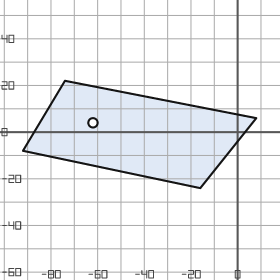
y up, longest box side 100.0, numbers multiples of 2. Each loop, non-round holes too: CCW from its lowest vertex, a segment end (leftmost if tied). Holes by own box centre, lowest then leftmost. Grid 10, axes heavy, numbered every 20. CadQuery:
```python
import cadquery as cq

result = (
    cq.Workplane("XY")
    .moveTo(-16.0, -24.0)
    .lineTo(8.0, 6.0)
    .lineTo(-74.0, 22.0)
    .lineTo(-92.0, -8.0)
    .close()
    .moveTo(-62.0, 4.0)
    .circle(2.0)
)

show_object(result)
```